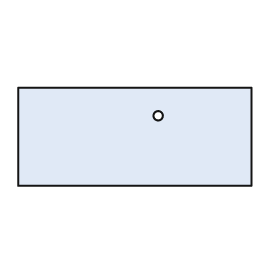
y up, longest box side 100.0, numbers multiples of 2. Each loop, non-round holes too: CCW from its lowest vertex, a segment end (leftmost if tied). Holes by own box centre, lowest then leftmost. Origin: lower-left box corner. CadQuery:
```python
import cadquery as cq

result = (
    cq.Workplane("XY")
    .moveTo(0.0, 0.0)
    .lineTo(100.0, 0.0)
    .lineTo(100.0, 42.0)
    .lineTo(0.0, 42.0)
    .close()
    .moveTo(60.0, 30.0)
    .circle(2.0)
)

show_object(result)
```